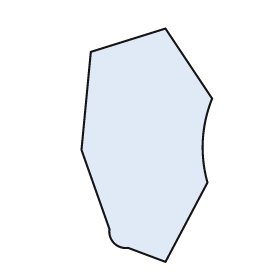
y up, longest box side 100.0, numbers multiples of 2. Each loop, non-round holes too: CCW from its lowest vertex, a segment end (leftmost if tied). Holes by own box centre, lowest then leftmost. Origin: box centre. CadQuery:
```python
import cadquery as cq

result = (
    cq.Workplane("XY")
    .moveTo(8.0, -50.0)
    .lineTo(26.0, -16.0)
    .threePointArc((24.0, 2.0), (28.0, 20.0))
    .lineTo(8.0, 50.0)
    .lineTo(-24.0, 40.0)
    .lineTo(-28.0, -2.0)
    .lineTo(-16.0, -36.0)
    .threePointArc((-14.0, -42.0), (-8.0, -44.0))
    .close()
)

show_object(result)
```